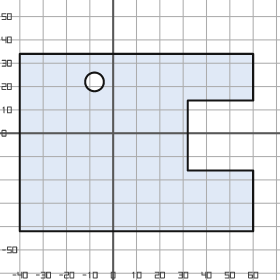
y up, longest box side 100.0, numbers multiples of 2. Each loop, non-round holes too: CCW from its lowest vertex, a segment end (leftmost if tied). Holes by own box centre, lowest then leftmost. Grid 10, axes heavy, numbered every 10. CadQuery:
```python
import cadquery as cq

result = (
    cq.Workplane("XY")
    .moveTo(-40.0, -42.0)
    .lineTo(60.0, -42.0)
    .lineTo(60.0, -16.0)
    .lineTo(32.0, -16.0)
    .lineTo(32.0, 14.0)
    .lineTo(60.0, 14.0)
    .lineTo(60.0, 34.0)
    .lineTo(-40.0, 34.0)
    .close()
    .moveTo(-8.0, 22.0)
    .circle(4.0)
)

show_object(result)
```